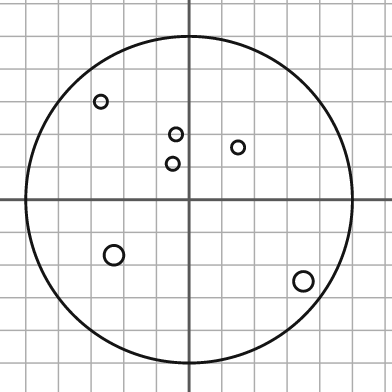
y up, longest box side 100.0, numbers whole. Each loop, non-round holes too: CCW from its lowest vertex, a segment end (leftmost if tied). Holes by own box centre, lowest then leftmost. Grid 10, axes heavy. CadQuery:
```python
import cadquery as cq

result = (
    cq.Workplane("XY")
    .moveTo(0.0, 0.0)
    .circle(50.0)
    .moveTo(35.0, -25.0)
    .circle(3.0)
    .moveTo(-23.0, -17.0)
    .circle(3.0)
    .moveTo(-5.0, 11.0)
    .circle(2.0)
    .moveTo(15.0, 16.0)
    .circle(2.0)
    .moveTo(-4.0, 20.0)
    .circle(2.0)
    .moveTo(-27.0, 30.0)
    .circle(2.0)
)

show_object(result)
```